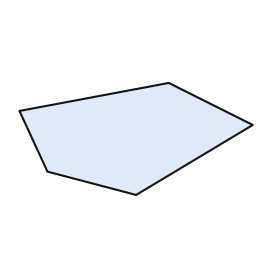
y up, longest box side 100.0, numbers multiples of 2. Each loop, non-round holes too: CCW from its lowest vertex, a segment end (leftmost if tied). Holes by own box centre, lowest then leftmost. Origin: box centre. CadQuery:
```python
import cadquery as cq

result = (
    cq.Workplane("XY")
    .moveTo(0.0, -24.0)
    .lineTo(50.0, 6.0)
    .lineTo(14.0, 24.0)
    .lineTo(-50.0, 12.0)
    .lineTo(-38.0, -14.0)
    .close()
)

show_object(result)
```